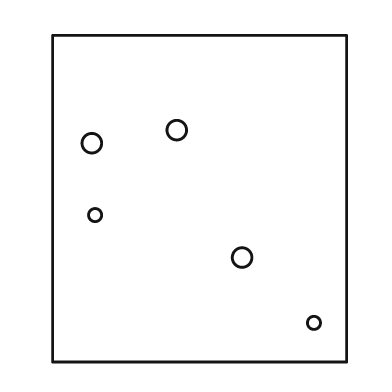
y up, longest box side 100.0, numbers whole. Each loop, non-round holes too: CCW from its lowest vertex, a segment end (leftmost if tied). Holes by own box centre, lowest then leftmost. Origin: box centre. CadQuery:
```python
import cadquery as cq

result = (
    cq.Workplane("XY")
    .moveTo(-45.0, -50.0)
    .lineTo(45.0, -50.0)
    .lineTo(45.0, 50.0)
    .lineTo(-45.0, 50.0)
    .close()
    .moveTo(35.0, -38.0)
    .circle(2.0)
    .moveTo(13.0, -18.0)
    .circle(3.0)
    .moveTo(-32.0, -5.0)
    .circle(2.0)
    .moveTo(-33.0, 17.0)
    .circle(3.0)
    .moveTo(-7.0, 21.0)
    .circle(3.0)
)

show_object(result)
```